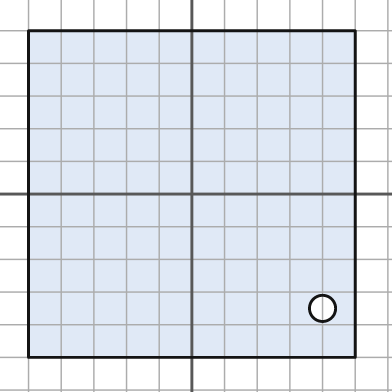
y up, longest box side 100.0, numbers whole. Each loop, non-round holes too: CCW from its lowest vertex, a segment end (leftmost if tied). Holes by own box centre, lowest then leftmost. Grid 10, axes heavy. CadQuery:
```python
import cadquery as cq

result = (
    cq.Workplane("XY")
    .moveTo(-50.0, -50.0)
    .lineTo(50.0, -50.0)
    .lineTo(50.0, 50.0)
    .lineTo(-50.0, 50.0)
    .close()
    .moveTo(40.0, -35.0)
    .circle(4.0)
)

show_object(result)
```